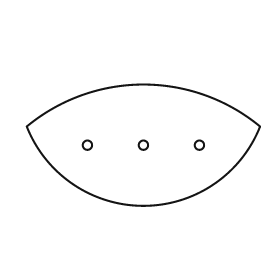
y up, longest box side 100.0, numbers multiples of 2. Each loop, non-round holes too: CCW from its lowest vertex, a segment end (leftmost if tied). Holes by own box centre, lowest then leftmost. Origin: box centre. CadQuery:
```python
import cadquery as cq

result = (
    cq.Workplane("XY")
    .moveTo(-50.0, 8.0)
    .threePointArc((0.0, -26.0), (50.0, 8.0))
    .threePointArc((0.0, 26.0), (-50.0, 8.0))
    .close()
    .moveTo(-24.0, 0.0)
    .circle(2.0)
    .moveTo(0.0, 0.0)
    .circle(2.0)
    .moveTo(24.0, 0.0)
    .circle(2.0)
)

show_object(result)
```